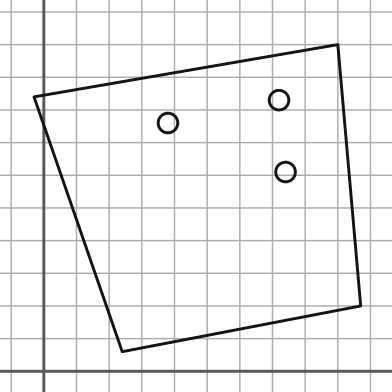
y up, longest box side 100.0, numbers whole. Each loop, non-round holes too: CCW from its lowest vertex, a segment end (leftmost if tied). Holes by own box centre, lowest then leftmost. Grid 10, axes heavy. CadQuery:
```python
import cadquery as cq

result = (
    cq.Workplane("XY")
    .moveTo(24.0, 6.0)
    .lineTo(97.0, 20.0)
    .lineTo(90.0, 100.0)
    .lineTo(-3.0, 84.0)
    .close()
    .moveTo(74.0, 61.0)
    .circle(3.0)
    .moveTo(38.0, 76.0)
    .circle(3.0)
    .moveTo(72.0, 83.0)
    .circle(3.0)
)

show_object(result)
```